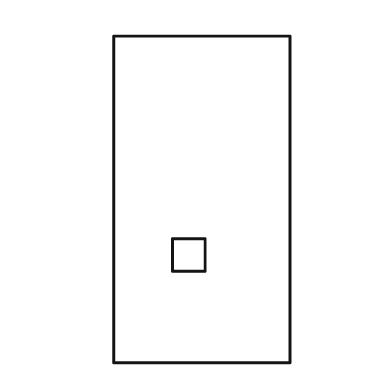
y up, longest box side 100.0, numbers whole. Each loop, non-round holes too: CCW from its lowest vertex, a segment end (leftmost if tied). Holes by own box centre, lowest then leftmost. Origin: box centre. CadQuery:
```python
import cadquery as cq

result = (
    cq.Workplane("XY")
    .moveTo(-27.0, -50.0)
    .lineTo(27.0, -50.0)
    .lineTo(27.0, 50.0)
    .lineTo(-27.0, 50.0)
    .close()
    .moveTo(-9.0, -22.0)
    .lineTo(1.0, -22.0)
    .lineTo(1.0, -12.0)
    .lineTo(-9.0, -12.0)
    .close()
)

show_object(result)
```